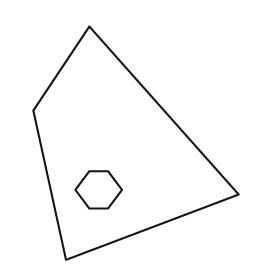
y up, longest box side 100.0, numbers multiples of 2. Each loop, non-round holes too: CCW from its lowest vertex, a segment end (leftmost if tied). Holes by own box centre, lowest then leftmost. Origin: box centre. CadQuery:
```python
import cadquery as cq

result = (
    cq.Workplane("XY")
    .moveTo(-30.0, -50.0)
    .lineTo(44.0, -22.0)
    .lineTo(-20.0, 50.0)
    .lineTo(-44.0, 14.0)
    .close()
    .moveTo(-20.0, -28.0)
    .lineTo(-12.0, -28.0)
    .lineTo(-6.0, -20.0)
    .lineTo(-12.0, -12.0)
    .lineTo(-20.0, -12.0)
    .lineTo(-26.0, -20.0)
    .close()
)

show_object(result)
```